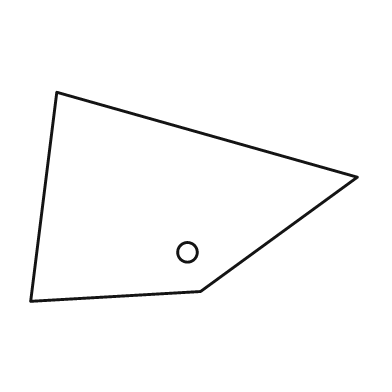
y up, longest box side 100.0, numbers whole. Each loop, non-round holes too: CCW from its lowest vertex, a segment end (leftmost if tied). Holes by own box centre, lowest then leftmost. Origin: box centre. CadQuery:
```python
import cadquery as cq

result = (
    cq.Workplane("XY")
    .moveTo(-50.0, -32.0)
    .lineTo(2.0, -29.0)
    .lineTo(50.0, 6.0)
    .lineTo(-42.0, 32.0)
    .close()
    .moveTo(-2.0, -17.0)
    .circle(3.0)
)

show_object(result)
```